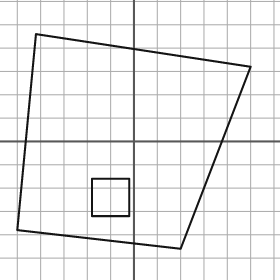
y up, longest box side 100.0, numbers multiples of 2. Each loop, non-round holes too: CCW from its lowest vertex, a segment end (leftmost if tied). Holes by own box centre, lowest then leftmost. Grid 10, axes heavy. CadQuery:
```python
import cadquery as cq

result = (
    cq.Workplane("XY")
    .moveTo(20.0, -46.0)
    .lineTo(50.0, 32.0)
    .lineTo(-42.0, 46.0)
    .lineTo(-50.0, -38.0)
    .close()
    .moveTo(-18.0, -32.0)
    .lineTo(-2.0, -32.0)
    .lineTo(-2.0, -16.0)
    .lineTo(-18.0, -16.0)
    .close()
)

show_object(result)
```